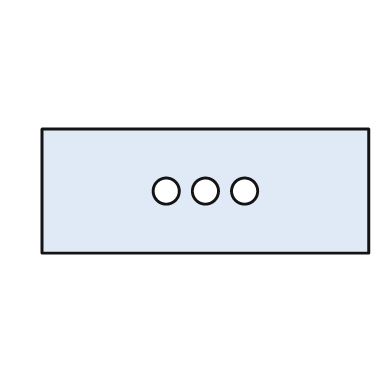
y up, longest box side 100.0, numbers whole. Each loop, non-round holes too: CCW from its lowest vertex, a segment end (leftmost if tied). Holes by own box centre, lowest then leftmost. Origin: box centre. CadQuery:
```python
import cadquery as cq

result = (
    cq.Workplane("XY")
    .moveTo(-50.0, -19.0)
    .lineTo(50.0, -19.0)
    .lineTo(50.0, 19.0)
    .lineTo(-50.0, 19.0)
    .close()
    .moveTo(-12.0, 0.0)
    .circle(4.0)
    .moveTo(0.0, 0.0)
    .circle(4.0)
    .moveTo(12.0, 0.0)
    .circle(4.0)
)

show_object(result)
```